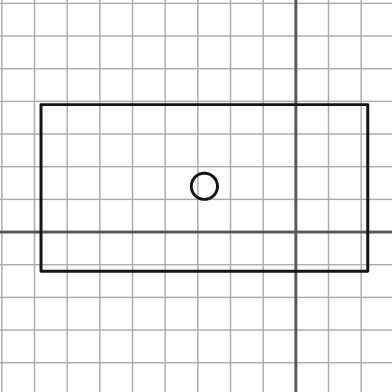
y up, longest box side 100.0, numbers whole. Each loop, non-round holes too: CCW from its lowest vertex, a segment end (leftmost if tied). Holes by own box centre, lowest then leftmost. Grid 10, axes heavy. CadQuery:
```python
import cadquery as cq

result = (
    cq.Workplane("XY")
    .moveTo(-78.0, -12.0)
    .lineTo(22.0, -12.0)
    .lineTo(22.0, 39.0)
    .lineTo(-78.0, 39.0)
    .close()
    .moveTo(-28.0, 14.0)
    .circle(4.0)
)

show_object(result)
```